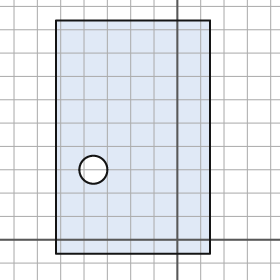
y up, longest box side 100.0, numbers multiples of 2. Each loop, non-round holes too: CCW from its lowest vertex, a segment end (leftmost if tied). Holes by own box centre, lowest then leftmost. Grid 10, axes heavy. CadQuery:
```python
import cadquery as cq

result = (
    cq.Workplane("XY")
    .moveTo(-52.0, -6.0)
    .lineTo(14.0, -6.0)
    .lineTo(14.0, 94.0)
    .lineTo(-52.0, 94.0)
    .close()
    .moveTo(-36.0, 30.0)
    .circle(6.0)
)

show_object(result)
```